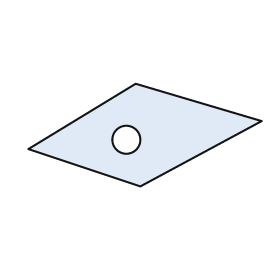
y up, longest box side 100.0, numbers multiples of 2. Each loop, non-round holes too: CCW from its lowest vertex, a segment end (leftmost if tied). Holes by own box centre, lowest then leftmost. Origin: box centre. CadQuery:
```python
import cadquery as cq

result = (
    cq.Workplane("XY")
    .moveTo(-2.0, -22.0)
    .lineTo(50.0, 6.0)
    .lineTo(-4.0, 22.0)
    .lineTo(-50.0, -6.0)
    .close()
    .moveTo(-8.0, -2.0)
    .circle(6.0)
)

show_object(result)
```